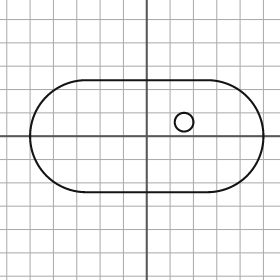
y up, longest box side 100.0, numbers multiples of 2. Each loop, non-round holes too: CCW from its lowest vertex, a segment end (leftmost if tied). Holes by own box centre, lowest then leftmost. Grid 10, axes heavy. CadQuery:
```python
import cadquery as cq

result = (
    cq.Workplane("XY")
    .moveTo(-26.0, -24.0)
    .lineTo(26.0, -24.0)
    .threePointArc((50.0, 0.0), (26.0, 24.0))
    .lineTo(-26.0, 24.0)
    .threePointArc((-50.0, 0.0), (-26.0, -24.0))
    .close()
    .moveTo(16.0, 6.0)
    .circle(4.0)
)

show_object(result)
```